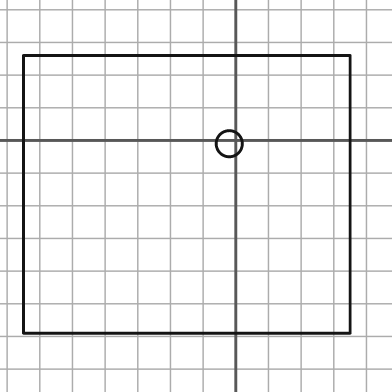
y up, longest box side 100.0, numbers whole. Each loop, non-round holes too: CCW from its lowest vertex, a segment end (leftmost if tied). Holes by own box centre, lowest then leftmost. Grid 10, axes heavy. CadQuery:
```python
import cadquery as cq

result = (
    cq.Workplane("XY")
    .moveTo(-65.0, -59.0)
    .lineTo(35.0, -59.0)
    .lineTo(35.0, 26.0)
    .lineTo(-65.0, 26.0)
    .close()
    .moveTo(-2.0, -1.0)
    .circle(4.0)
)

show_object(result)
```